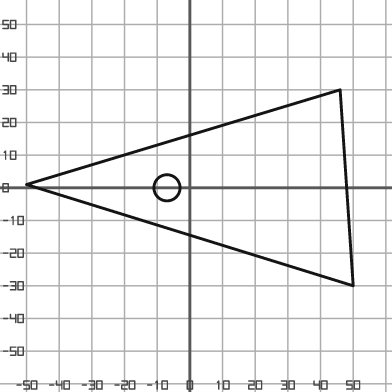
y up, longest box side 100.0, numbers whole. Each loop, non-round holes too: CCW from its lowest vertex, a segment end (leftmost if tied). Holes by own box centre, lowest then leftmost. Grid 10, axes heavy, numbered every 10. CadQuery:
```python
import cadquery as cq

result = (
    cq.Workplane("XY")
    .moveTo(50.0, -30.0)
    .lineTo(46.0, 30.0)
    .lineTo(-50.0, 1.0)
    .close()
    .moveTo(-7.0, 0.0)
    .circle(4.0)
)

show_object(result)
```